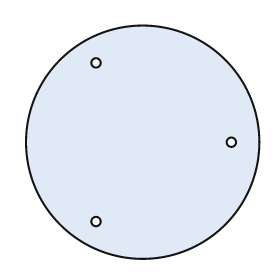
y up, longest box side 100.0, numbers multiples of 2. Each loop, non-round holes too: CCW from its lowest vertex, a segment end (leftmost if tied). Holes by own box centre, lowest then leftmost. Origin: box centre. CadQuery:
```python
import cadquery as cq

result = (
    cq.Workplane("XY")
    .moveTo(0.0, 0.0)
    .circle(50.0)
    .moveTo(-20.0, -34.0)
    .circle(2.0)
    .moveTo(38.0, 0.0)
    .circle(2.0)
    .moveTo(-20.0, 34.0)
    .circle(2.0)
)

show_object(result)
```